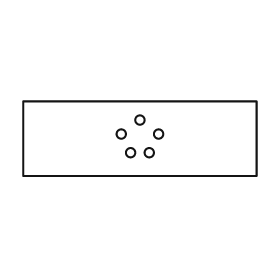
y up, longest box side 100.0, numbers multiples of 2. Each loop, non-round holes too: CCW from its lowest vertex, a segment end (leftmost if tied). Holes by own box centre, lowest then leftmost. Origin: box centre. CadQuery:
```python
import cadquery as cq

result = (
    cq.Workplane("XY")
    .moveTo(-50.0, -16.0)
    .lineTo(50.0, -16.0)
    .lineTo(50.0, 16.0)
    .lineTo(-50.0, 16.0)
    .close()
    .moveTo(-4.0, -6.0)
    .circle(2.0)
    .moveTo(4.0, -6.0)
    .circle(2.0)
    .moveTo(-8.0, 2.0)
    .circle(2.0)
    .moveTo(8.0, 2.0)
    .circle(2.0)
    .moveTo(0.0, 8.0)
    .circle(2.0)
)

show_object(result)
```